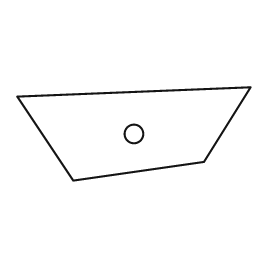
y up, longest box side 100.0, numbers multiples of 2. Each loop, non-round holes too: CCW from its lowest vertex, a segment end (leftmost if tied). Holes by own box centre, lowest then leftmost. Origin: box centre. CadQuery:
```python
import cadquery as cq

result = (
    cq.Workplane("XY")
    .moveTo(-26.0, -20.0)
    .lineTo(30.0, -12.0)
    .lineTo(50.0, 20.0)
    .lineTo(-50.0, 16.0)
    .close()
    .moveTo(0.0, 0.0)
    .circle(4.0)
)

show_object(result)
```